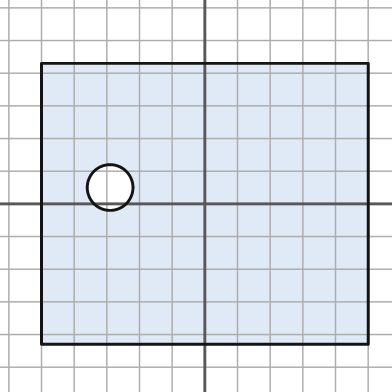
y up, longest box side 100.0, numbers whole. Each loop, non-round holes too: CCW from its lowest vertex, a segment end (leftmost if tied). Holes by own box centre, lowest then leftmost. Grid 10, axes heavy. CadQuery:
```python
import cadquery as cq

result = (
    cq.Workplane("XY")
    .moveTo(-50.0, -43.0)
    .lineTo(50.0, -43.0)
    .lineTo(50.0, 43.0)
    .lineTo(-50.0, 43.0)
    .close()
    .moveTo(-29.0, 5.0)
    .circle(7.0)
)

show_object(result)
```